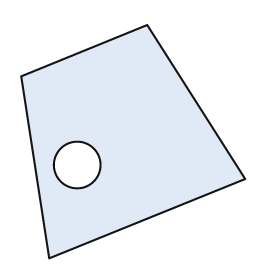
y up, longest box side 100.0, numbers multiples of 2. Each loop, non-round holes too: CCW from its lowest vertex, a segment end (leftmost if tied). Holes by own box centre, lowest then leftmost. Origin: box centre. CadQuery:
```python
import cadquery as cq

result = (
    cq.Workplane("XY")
    .moveTo(-36.0, -50.0)
    .lineTo(48.0, -16.0)
    .lineTo(6.0, 50.0)
    .lineTo(-48.0, 28.0)
    .close()
    .moveTo(-24.0, -10.0)
    .circle(10.0)
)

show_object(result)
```